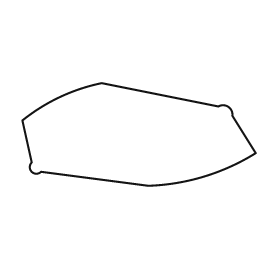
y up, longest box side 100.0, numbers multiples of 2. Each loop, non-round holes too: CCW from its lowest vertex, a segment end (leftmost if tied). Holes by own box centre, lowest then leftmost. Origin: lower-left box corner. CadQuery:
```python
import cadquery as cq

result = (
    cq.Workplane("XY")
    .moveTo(54.0, 0.0)
    .threePointArc((78.0, 4.0), (100.0, 14.0))
    .lineTo(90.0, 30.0)
    .threePointArc((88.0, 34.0), (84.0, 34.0))
    .lineTo(34.0, 44.0)
    .threePointArc((16.0, 38.0), (0.0, 28.0))
    .lineTo(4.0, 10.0)
    .threePointArc((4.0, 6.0), (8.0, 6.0))
    .close()
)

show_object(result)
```